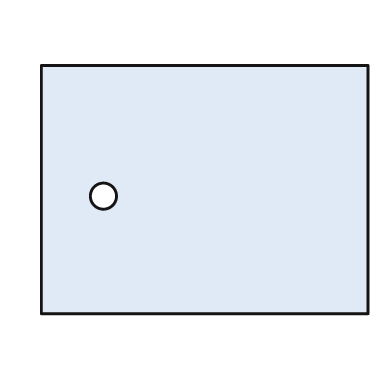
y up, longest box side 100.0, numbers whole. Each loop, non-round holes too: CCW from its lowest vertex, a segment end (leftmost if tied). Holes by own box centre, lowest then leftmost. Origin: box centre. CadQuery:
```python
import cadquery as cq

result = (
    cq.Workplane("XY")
    .moveTo(-50.0, -38.0)
    .lineTo(50.0, -38.0)
    .lineTo(50.0, 38.0)
    .lineTo(-50.0, 38.0)
    .close()
    .moveTo(-31.0, -2.0)
    .circle(4.0)
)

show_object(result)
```